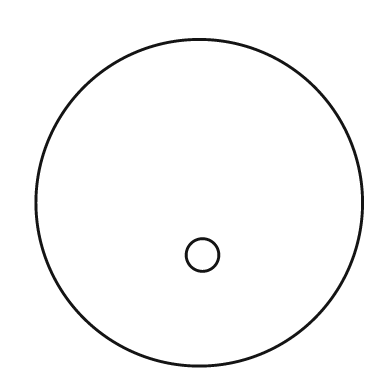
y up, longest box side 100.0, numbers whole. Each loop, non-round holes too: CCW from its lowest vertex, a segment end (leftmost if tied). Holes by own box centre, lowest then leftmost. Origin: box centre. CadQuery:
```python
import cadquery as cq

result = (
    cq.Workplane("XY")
    .moveTo(0.0, 0.0)
    .circle(50.0)
    .moveTo(1.0, -16.0)
    .circle(5.0)
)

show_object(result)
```